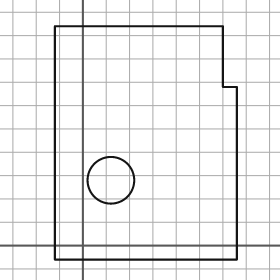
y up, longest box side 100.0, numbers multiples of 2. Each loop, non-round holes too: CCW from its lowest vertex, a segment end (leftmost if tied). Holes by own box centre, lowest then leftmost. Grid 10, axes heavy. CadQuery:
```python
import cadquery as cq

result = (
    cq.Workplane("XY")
    .moveTo(-12.0, -6.0)
    .lineTo(66.0, -6.0)
    .lineTo(66.0, 68.0)
    .lineTo(60.0, 68.0)
    .lineTo(60.0, 94.0)
    .lineTo(-12.0, 94.0)
    .close()
    .moveTo(12.0, 28.0)
    .circle(10.0)
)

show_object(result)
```